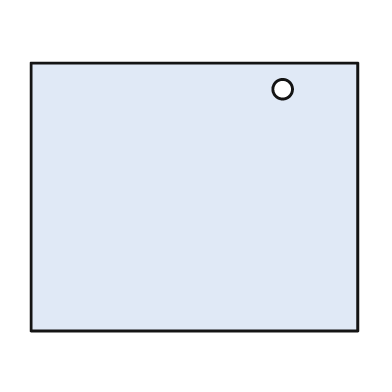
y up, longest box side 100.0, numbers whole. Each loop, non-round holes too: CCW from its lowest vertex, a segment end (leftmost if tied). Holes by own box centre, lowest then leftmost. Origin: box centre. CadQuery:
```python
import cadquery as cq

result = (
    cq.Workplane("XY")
    .moveTo(-50.0, -41.0)
    .lineTo(50.0, -41.0)
    .lineTo(50.0, 41.0)
    .lineTo(-50.0, 41.0)
    .close()
    .moveTo(27.0, 33.0)
    .circle(3.0)
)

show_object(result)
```